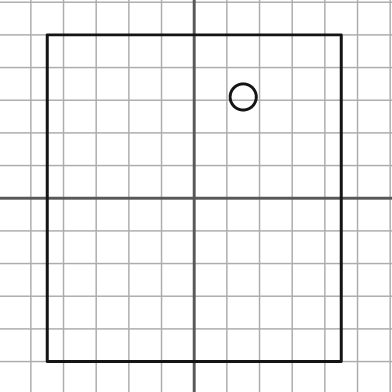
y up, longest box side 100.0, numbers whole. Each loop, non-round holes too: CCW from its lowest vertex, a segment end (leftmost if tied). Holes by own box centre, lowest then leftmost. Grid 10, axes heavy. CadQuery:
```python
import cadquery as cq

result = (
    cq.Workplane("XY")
    .moveTo(-45.0, -50.0)
    .lineTo(45.0, -50.0)
    .lineTo(45.0, 50.0)
    .lineTo(-45.0, 50.0)
    .close()
    .moveTo(15.0, 31.0)
    .circle(4.0)
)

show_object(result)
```